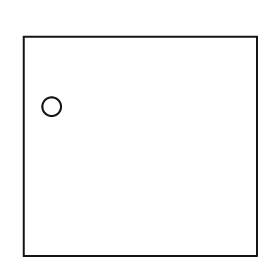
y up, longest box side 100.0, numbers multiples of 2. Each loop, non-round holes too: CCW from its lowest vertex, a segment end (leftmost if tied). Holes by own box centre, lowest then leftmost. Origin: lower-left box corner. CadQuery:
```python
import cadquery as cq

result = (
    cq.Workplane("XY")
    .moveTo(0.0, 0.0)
    .lineTo(100.0, 0.0)
    .lineTo(100.0, 94.0)
    .lineTo(0.0, 94.0)
    .close()
    .moveTo(12.0, 64.0)
    .circle(4.0)
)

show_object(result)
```